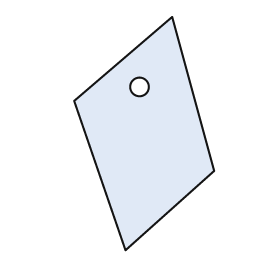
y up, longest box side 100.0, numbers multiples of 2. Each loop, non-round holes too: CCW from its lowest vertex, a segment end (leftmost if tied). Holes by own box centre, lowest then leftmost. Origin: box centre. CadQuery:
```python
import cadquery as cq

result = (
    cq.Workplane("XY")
    .moveTo(-8.0, -50.0)
    .lineTo(30.0, -16.0)
    .lineTo(12.0, 50.0)
    .lineTo(-30.0, 14.0)
    .close()
    .moveTo(-2.0, 20.0)
    .circle(4.0)
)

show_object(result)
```